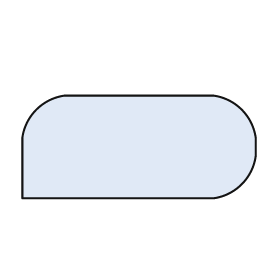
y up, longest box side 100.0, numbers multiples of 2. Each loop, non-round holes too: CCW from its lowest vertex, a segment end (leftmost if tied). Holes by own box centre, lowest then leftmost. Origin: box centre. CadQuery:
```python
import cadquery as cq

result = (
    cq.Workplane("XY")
    .moveTo(-50.0, -22.0)
    .lineTo(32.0, -22.0)
    .threePointArc((44.0, -16.0), (50.0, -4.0))
    .lineTo(50.0, 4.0)
    .threePointArc((44.0, 16.0), (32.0, 22.0))
    .lineTo(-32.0, 22.0)
    .threePointArc((-44.0, 16.0), (-50.0, 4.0))
    .close()
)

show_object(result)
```